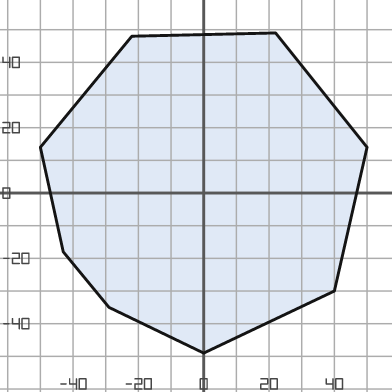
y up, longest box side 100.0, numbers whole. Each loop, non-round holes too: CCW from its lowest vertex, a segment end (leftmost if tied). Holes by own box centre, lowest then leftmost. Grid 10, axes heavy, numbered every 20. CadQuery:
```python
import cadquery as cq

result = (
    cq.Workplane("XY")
    .moveTo(0.0, -49.0)
    .lineTo(40.0, -30.0)
    .lineTo(50.0, 14.0)
    .lineTo(22.0, 49.0)
    .lineTo(-22.0, 48.0)
    .lineTo(-50.0, 14.0)
    .lineTo(-43.0, -18.0)
    .lineTo(-29.0, -35.0)
    .close()
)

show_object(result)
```